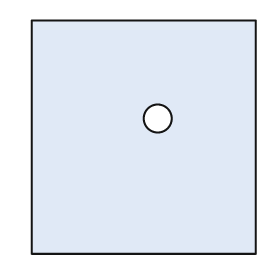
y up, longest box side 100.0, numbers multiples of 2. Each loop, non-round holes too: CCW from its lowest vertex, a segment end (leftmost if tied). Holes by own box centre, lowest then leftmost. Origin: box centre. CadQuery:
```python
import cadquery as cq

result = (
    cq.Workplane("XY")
    .moveTo(-48.0, -50.0)
    .lineTo(48.0, -50.0)
    .lineTo(48.0, 50.0)
    .lineTo(-48.0, 50.0)
    .close()
    .moveTo(6.0, 8.0)
    .circle(6.0)
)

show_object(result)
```